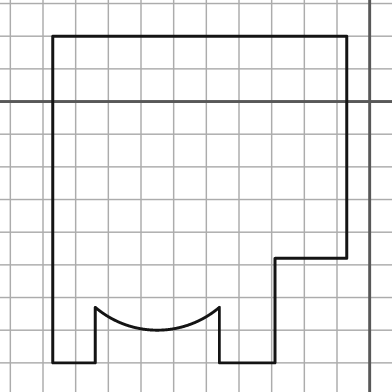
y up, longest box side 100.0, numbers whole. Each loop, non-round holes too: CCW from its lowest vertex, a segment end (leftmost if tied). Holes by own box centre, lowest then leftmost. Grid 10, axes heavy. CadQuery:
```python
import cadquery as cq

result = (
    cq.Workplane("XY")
    .moveTo(-97.0, -80.0)
    .lineTo(-84.0, -80.0)
    .lineTo(-84.0, -63.0)
    .threePointArc((-65.0, -70.0), (-46.0, -63.0))
    .lineTo(-46.0, -80.0)
    .lineTo(-29.0, -80.0)
    .lineTo(-29.0, -48.0)
    .lineTo(-7.0, -48.0)
    .lineTo(-7.0, 20.0)
    .lineTo(-97.0, 20.0)
    .close()
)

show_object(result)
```